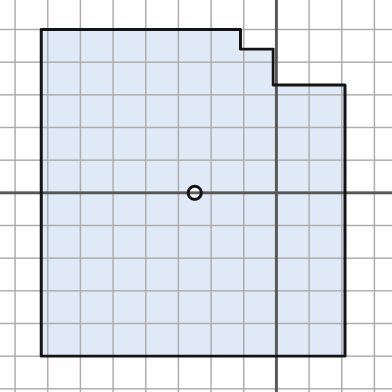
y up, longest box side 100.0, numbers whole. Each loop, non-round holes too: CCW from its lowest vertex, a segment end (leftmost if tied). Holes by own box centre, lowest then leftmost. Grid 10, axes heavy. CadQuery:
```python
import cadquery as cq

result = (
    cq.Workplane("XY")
    .moveTo(-72.0, -50.0)
    .lineTo(21.0, -50.0)
    .lineTo(21.0, 33.0)
    .lineTo(-1.0, 33.0)
    .lineTo(-1.0, 44.0)
    .lineTo(-11.0, 44.0)
    .lineTo(-11.0, 50.0)
    .lineTo(-72.0, 50.0)
    .close()
    .moveTo(-25.0, 0.0)
    .circle(2.0)
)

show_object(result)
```